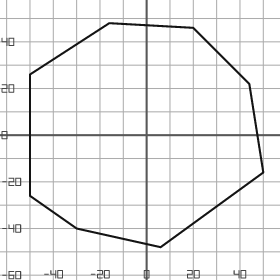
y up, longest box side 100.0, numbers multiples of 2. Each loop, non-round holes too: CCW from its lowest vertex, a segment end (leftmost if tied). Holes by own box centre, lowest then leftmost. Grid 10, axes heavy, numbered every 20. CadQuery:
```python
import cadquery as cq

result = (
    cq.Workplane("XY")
    .moveTo(6.0, -48.0)
    .lineTo(50.0, -16.0)
    .lineTo(44.0, 22.0)
    .lineTo(20.0, 46.0)
    .lineTo(-16.0, 48.0)
    .lineTo(-50.0, 26.0)
    .lineTo(-50.0, -26.0)
    .lineTo(-30.0, -40.0)
    .close()
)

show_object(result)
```